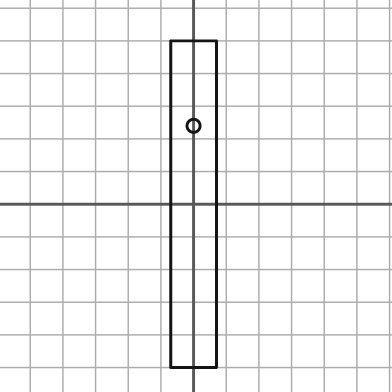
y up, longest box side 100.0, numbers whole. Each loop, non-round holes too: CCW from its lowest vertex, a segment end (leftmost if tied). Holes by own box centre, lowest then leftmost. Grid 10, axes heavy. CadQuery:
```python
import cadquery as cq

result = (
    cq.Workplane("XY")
    .moveTo(-7.0, -50.0)
    .lineTo(7.0, -50.0)
    .lineTo(7.0, 50.0)
    .lineTo(-7.0, 50.0)
    .close()
    .moveTo(0.0, 24.0)
    .circle(2.0)
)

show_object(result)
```